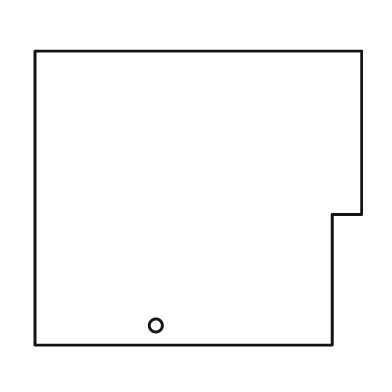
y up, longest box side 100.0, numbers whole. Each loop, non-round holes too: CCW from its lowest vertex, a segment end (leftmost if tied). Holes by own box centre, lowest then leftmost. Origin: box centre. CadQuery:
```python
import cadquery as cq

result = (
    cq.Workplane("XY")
    .moveTo(-50.0, -45.0)
    .lineTo(41.0, -45.0)
    .lineTo(41.0, -5.0)
    .lineTo(50.0, -5.0)
    .lineTo(50.0, 45.0)
    .lineTo(-50.0, 45.0)
    .close()
    .moveTo(-13.0, -39.0)
    .circle(2.0)
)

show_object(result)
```